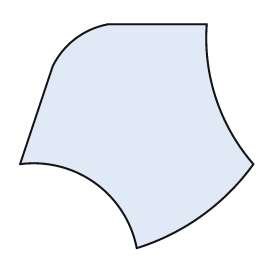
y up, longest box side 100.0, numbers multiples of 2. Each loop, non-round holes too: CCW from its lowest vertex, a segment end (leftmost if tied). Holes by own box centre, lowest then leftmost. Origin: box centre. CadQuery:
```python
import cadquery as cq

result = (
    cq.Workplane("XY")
    .moveTo(0.0, -48.0)
    .threePointArc((28.0, -34.0), (50.0, -12.0))
    .threePointArc((34.0, 16.0), (30.0, 48.0))
    .lineTo(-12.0, 48.0)
    .threePointArc((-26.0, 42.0), (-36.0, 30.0))
    .lineTo(-50.0, -12.0)
    .threePointArc((-18.0, -20.0), (0.0, -48.0))
    .close()
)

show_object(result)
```